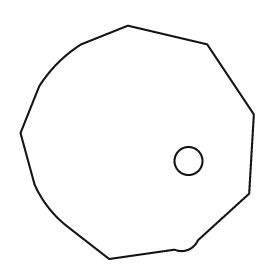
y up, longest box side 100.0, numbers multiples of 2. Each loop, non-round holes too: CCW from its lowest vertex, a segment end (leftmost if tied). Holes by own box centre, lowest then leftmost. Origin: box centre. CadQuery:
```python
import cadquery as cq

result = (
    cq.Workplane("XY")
    .moveTo(-12.0, -50.0)
    .lineTo(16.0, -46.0)
    .threePointArc((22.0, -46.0), (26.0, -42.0))
    .lineTo(48.0, -22.0)
    .lineTo(50.0, 12.0)
    .lineTo(30.0, 42.0)
    .lineTo(-4.0, 50.0)
    .lineTo(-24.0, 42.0)
    .threePointArc((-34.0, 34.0), (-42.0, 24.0))
    .lineTo(-50.0, 4.0)
    .lineTo(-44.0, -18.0)
    .threePointArc((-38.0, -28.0), (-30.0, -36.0))
    .close()
    .moveTo(22.0, -8.0)
    .circle(6.0)
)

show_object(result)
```